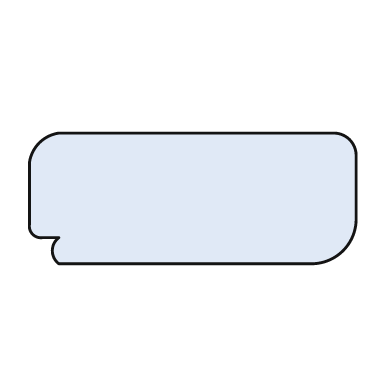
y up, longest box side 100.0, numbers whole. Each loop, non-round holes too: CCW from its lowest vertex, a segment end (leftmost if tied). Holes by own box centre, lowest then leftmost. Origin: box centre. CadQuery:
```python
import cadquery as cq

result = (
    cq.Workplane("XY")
    .moveTo(-41.0, -20.0)
    .lineTo(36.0, -20.0)
    .threePointArc((46.0, -16.0), (50.0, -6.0))
    .lineTo(50.0, 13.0)
    .threePointArc((48.0, 18.0), (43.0, 20.0))
    .lineTo(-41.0, 20.0)
    .threePointArc((-47.0, 17.0), (-50.0, 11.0))
    .lineTo(-50.0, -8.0)
    .threePointArc((-49.0, -11.0), (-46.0, -12.0))
    .lineTo(-41.0, -12.0)
    .threePointArc((-43.0, -16.0), (-41.0, -20.0))
    .close()
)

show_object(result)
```